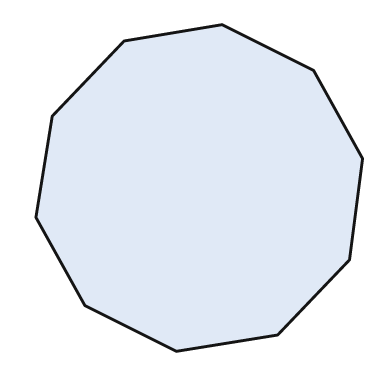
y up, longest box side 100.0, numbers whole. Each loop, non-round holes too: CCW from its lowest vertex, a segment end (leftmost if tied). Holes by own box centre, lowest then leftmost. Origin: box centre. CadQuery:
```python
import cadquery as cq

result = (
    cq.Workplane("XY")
    .moveTo(-7.0, -50.0)
    .lineTo(24.0, -45.0)
    .lineTo(46.0, -22.0)
    .lineTo(50.0, 9.0)
    .lineTo(35.0, 36.0)
    .lineTo(7.0, 50.0)
    .lineTo(-23.0, 45.0)
    .lineTo(-45.0, 22.0)
    .lineTo(-50.0, -9.0)
    .lineTo(-35.0, -36.0)
    .close()
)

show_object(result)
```